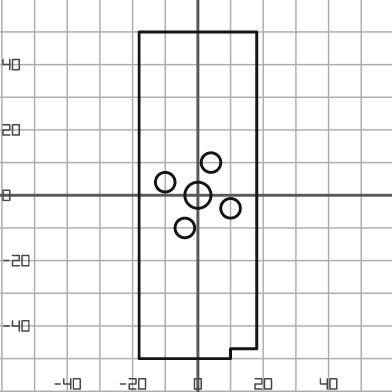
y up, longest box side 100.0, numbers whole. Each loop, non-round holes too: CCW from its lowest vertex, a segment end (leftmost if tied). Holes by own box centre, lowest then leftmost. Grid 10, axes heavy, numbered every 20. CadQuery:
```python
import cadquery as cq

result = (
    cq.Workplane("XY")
    .moveTo(-18.0, -50.0)
    .lineTo(10.0, -50.0)
    .lineTo(10.0, -47.0)
    .lineTo(18.0, -47.0)
    .lineTo(18.0, 50.0)
    .lineTo(-18.0, 50.0)
    .close()
    .moveTo(-4.0, -10.0)
    .circle(3.0)
    .moveTo(10.0, -4.0)
    .circle(3.0)
    .moveTo(0.0, 0.0)
    .circle(4.0)
    .moveTo(-10.0, 4.0)
    .circle(3.0)
    .moveTo(4.0, 10.0)
    .circle(3.0)
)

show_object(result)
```